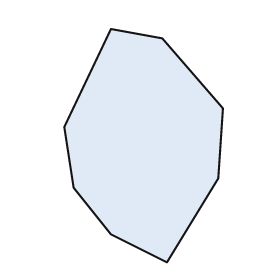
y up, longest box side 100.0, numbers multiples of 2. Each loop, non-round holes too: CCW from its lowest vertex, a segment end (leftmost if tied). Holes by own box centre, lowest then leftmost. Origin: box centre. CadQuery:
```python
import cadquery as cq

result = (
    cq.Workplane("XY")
    .moveTo(10.0, -50.0)
    .lineTo(32.0, -14.0)
    .lineTo(34.0, 16.0)
    .lineTo(8.0, 46.0)
    .lineTo(-14.0, 50.0)
    .lineTo(-34.0, 8.0)
    .lineTo(-30.0, -18.0)
    .lineTo(-14.0, -38.0)
    .close()
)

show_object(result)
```